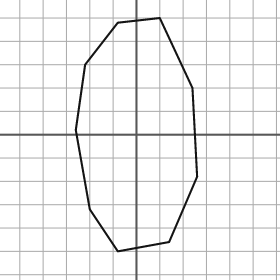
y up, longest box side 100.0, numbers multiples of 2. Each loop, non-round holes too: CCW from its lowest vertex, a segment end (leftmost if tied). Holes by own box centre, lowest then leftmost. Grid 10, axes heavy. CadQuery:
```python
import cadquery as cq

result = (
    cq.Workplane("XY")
    .moveTo(-8.0, -50.0)
    .lineTo(14.0, -46.0)
    .lineTo(26.0, -18.0)
    .lineTo(24.0, 20.0)
    .lineTo(10.0, 50.0)
    .lineTo(-8.0, 48.0)
    .lineTo(-22.0, 30.0)
    .lineTo(-26.0, 2.0)
    .lineTo(-20.0, -32.0)
    .close()
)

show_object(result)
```